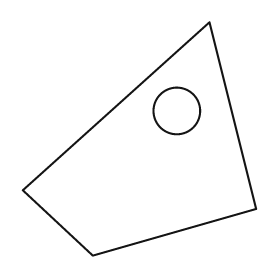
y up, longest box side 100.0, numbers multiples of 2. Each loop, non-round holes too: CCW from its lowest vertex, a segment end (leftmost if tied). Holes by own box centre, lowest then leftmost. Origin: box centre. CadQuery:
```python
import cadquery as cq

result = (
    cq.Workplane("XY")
    .moveTo(-20.0, -50.0)
    .lineTo(50.0, -30.0)
    .lineTo(30.0, 50.0)
    .lineTo(-50.0, -22.0)
    .close()
    .moveTo(16.0, 12.0)
    .circle(10.0)
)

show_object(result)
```